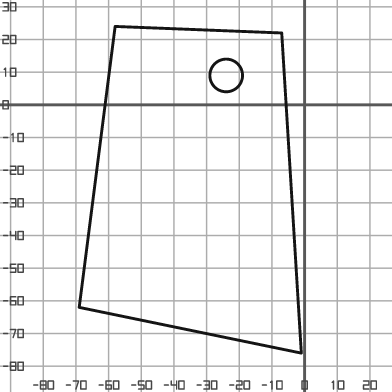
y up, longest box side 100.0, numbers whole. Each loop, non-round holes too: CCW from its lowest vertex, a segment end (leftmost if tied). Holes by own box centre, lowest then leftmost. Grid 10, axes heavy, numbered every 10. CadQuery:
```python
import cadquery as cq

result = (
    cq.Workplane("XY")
    .moveTo(-1.0, -76.0)
    .lineTo(-7.0, 22.0)
    .lineTo(-58.0, 24.0)
    .lineTo(-69.0, -62.0)
    .close()
    .moveTo(-24.0, 9.0)
    .circle(5.0)
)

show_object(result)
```